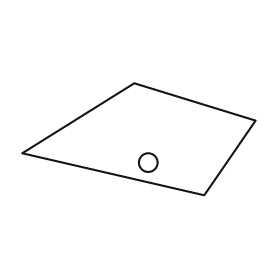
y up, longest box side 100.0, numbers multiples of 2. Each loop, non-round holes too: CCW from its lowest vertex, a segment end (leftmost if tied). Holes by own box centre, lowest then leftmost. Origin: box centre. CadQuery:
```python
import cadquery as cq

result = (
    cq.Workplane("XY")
    .moveTo(28.0, -24.0)
    .lineTo(50.0, 8.0)
    .lineTo(-2.0, 24.0)
    .lineTo(-50.0, -6.0)
    .close()
    .moveTo(4.0, -10.0)
    .circle(4.0)
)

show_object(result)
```